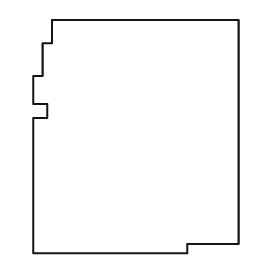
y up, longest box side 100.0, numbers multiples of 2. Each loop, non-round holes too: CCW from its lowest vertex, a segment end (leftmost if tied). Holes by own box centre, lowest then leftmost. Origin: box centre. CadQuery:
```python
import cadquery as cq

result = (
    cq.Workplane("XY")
    .moveTo(-44.0, -50.0)
    .lineTo(22.0, -50.0)
    .lineTo(22.0, -46.0)
    .lineTo(44.0, -46.0)
    .lineTo(44.0, 50.0)
    .lineTo(-36.0, 50.0)
    .lineTo(-36.0, 40.0)
    .lineTo(-40.0, 40.0)
    .lineTo(-40.0, 26.0)
    .lineTo(-44.0, 26.0)
    .lineTo(-44.0, 14.0)
    .lineTo(-38.0, 14.0)
    .lineTo(-38.0, 8.0)
    .lineTo(-44.0, 8.0)
    .close()
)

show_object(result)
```